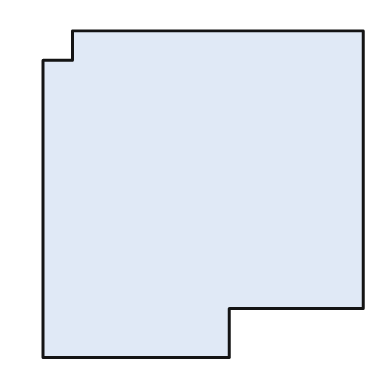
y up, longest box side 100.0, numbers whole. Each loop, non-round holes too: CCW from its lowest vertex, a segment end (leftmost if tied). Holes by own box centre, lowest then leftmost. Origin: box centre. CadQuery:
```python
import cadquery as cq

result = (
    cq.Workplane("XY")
    .moveTo(-49.0, -50.0)
    .lineTo(8.0, -50.0)
    .lineTo(8.0, -35.0)
    .lineTo(49.0, -35.0)
    .lineTo(49.0, 50.0)
    .lineTo(-40.0, 50.0)
    .lineTo(-40.0, 41.0)
    .lineTo(-49.0, 41.0)
    .close()
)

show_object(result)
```